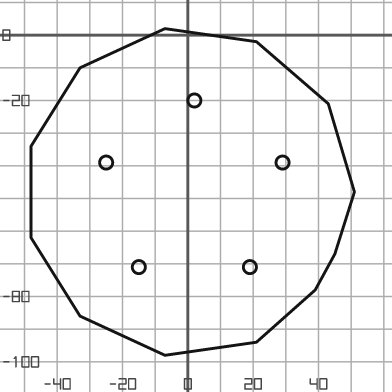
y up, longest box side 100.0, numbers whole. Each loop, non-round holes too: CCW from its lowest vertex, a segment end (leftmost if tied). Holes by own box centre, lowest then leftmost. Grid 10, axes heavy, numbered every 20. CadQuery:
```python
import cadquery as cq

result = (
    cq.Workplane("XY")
    .moveTo(-7.0, -98.0)
    .lineTo(21.0, -94.0)
    .lineTo(39.0, -78.0)
    .lineTo(45.0, -67.0)
    .lineTo(51.0, -48.0)
    .lineTo(43.0, -21.0)
    .lineTo(21.0, -2.0)
    .lineTo(-7.0, 2.0)
    .lineTo(-33.0, -10.0)
    .lineTo(-48.0, -34.0)
    .lineTo(-48.0, -62.0)
    .lineTo(-33.0, -86.0)
    .close()
    .moveTo(-15.0, -71.0)
    .circle(2.0)
    .moveTo(19.0, -71.0)
    .circle(2.0)
    .moveTo(-25.0, -39.0)
    .circle(2.0)
    .moveTo(29.0, -39.0)
    .circle(2.0)
    .moveTo(2.0, -20.0)
    .circle(2.0)
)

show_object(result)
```